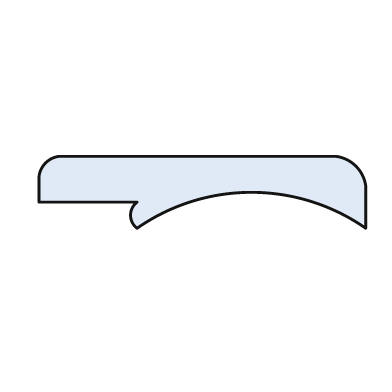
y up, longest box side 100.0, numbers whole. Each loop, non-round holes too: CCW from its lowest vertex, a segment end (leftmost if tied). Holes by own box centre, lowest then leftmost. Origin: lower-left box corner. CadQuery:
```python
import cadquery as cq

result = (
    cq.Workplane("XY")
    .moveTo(30.0, 0.0)
    .threePointArc((65.0, 11.0), (100.0, 0.0))
    .lineTo(100.0, 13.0)
    .threePointArc((97.0, 19.0), (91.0, 22.0))
    .lineTo(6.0, 22.0)
    .threePointArc((2.0, 20.0), (0.0, 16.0))
    .lineTo(0.0, 8.0)
    .lineTo(30.0, 8.0)
    .threePointArc((28.0, 4.0), (30.0, 0.0))
    .close()
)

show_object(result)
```